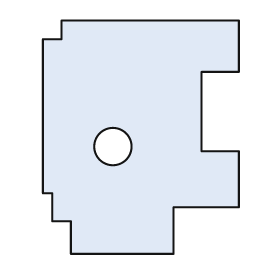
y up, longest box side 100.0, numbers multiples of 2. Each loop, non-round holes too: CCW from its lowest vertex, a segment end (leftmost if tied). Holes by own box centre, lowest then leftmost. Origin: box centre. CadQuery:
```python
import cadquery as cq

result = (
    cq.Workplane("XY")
    .moveTo(-30.0, -50.0)
    .lineTo(14.0, -50.0)
    .lineTo(14.0, -30.0)
    .lineTo(42.0, -30.0)
    .lineTo(42.0, -6.0)
    .lineTo(26.0, -6.0)
    .lineTo(26.0, 28.0)
    .lineTo(42.0, 28.0)
    .lineTo(42.0, 50.0)
    .lineTo(-34.0, 50.0)
    .lineTo(-34.0, 42.0)
    .lineTo(-42.0, 42.0)
    .lineTo(-42.0, -24.0)
    .lineTo(-38.0, -24.0)
    .lineTo(-38.0, -36.0)
    .lineTo(-30.0, -36.0)
    .close()
    .moveTo(-12.0, -4.0)
    .circle(8.0)
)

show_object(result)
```